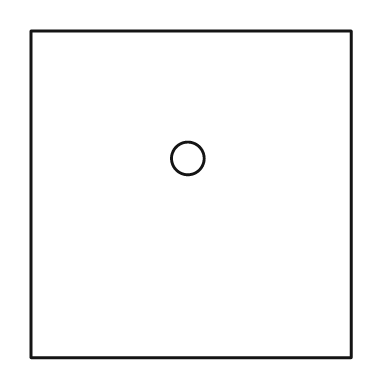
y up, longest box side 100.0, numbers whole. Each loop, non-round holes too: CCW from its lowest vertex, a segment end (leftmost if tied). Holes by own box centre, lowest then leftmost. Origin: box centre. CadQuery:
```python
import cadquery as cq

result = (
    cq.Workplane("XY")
    .moveTo(-49.0, -50.0)
    .lineTo(49.0, -50.0)
    .lineTo(49.0, 50.0)
    .lineTo(-49.0, 50.0)
    .close()
    .moveTo(-1.0, 11.0)
    .circle(5.0)
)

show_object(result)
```